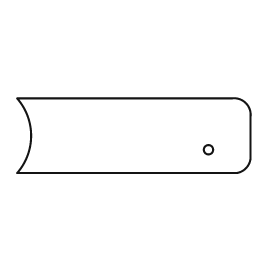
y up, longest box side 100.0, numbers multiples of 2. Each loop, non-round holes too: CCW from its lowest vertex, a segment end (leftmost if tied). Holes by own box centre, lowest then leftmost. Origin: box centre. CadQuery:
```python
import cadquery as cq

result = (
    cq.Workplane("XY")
    .moveTo(-50.0, -16.0)
    .lineTo(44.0, -16.0)
    .threePointArc((48.0, -14.0), (50.0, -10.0))
    .lineTo(50.0, 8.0)
    .threePointArc((48.0, 14.0), (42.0, 16.0))
    .lineTo(-50.0, 16.0)
    .threePointArc((-44.0, 0.0), (-50.0, -16.0))
    .close()
    .moveTo(32.0, -6.0)
    .circle(2.0)
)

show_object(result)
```